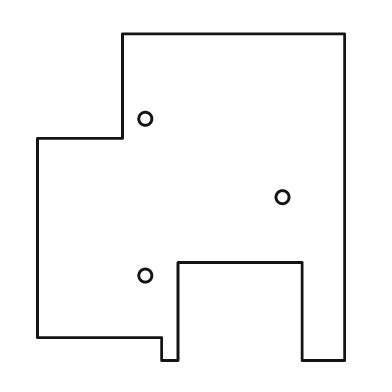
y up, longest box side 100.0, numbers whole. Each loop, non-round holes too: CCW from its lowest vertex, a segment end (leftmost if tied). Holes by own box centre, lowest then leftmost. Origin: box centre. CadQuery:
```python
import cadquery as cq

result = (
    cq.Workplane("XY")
    .moveTo(-9.0, -50.0)
    .lineTo(-4.0, -50.0)
    .lineTo(-4.0, -20.0)
    .lineTo(34.0, -20.0)
    .lineTo(34.0, -50.0)
    .lineTo(47.0, -50.0)
    .lineTo(47.0, 50.0)
    .lineTo(-21.0, 50.0)
    .lineTo(-21.0, 18.0)
    .lineTo(-47.0, 18.0)
    .lineTo(-47.0, -43.0)
    .lineTo(-9.0, -43.0)
    .close()
    .moveTo(-14.0, -24.0)
    .circle(2.0)
    .moveTo(28.0, 0.0)
    .circle(2.0)
    .moveTo(-14.0, 24.0)
    .circle(2.0)
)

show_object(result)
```